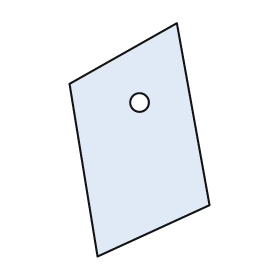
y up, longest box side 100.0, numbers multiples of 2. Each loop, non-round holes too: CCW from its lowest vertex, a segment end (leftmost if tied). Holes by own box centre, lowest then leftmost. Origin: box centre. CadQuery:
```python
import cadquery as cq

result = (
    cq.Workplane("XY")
    .moveTo(-18.0, -50.0)
    .lineTo(30.0, -28.0)
    .lineTo(16.0, 50.0)
    .lineTo(-30.0, 24.0)
    .close()
    .moveTo(0.0, 16.0)
    .circle(4.0)
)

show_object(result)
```